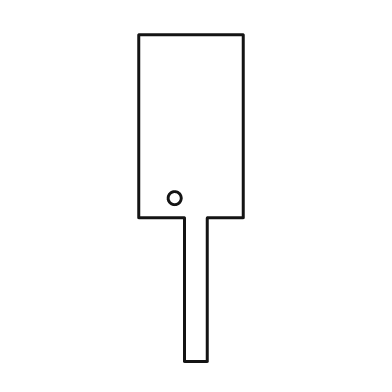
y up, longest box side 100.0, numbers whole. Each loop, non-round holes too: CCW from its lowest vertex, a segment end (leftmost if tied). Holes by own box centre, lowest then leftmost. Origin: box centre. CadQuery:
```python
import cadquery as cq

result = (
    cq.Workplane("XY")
    .moveTo(-2.0, -50.0)
    .lineTo(5.0, -50.0)
    .lineTo(5.0, -6.0)
    .lineTo(16.0, -6.0)
    .lineTo(16.0, 50.0)
    .lineTo(-16.0, 50.0)
    .lineTo(-16.0, -6.0)
    .lineTo(-2.0, -6.0)
    .close()
    .moveTo(-5.0, 0.0)
    .circle(2.0)
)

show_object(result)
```